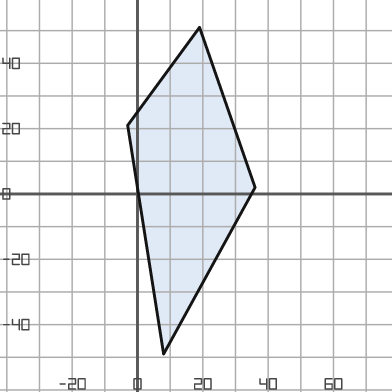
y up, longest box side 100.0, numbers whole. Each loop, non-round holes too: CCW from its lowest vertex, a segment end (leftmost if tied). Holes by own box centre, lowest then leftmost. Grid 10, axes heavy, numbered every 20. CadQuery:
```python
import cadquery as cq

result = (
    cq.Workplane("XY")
    .moveTo(8.0, -49.0)
    .lineTo(36.0, 2.0)
    .lineTo(19.0, 51.0)
    .lineTo(-3.0, 21.0)
    .close()
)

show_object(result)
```